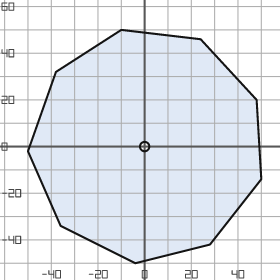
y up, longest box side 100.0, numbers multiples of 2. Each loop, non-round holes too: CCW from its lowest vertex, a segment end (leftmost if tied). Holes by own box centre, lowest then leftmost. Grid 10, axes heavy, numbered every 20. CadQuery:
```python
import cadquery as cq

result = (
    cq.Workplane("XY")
    .moveTo(-4.0, -50.0)
    .lineTo(28.0, -42.0)
    .lineTo(50.0, -14.0)
    .lineTo(48.0, 20.0)
    .lineTo(24.0, 46.0)
    .lineTo(-10.0, 50.0)
    .lineTo(-38.0, 32.0)
    .lineTo(-50.0, -2.0)
    .lineTo(-36.0, -34.0)
    .close()
    .moveTo(0.0, 0.0)
    .circle(2.0)
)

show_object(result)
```